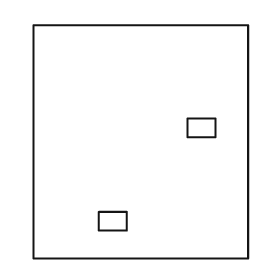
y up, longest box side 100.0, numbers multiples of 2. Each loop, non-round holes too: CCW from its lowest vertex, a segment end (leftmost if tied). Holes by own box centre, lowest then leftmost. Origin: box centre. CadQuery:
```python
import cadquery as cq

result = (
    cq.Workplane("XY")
    .moveTo(-46.0, -50.0)
    .lineTo(46.0, -50.0)
    .lineTo(46.0, 50.0)
    .lineTo(-46.0, 50.0)
    .close()
    .moveTo(-18.0, -38.0)
    .lineTo(-6.0, -38.0)
    .lineTo(-6.0, -30.0)
    .lineTo(-18.0, -30.0)
    .close()
    .moveTo(20.0, 2.0)
    .lineTo(32.0, 2.0)
    .lineTo(32.0, 10.0)
    .lineTo(20.0, 10.0)
    .close()
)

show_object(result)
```